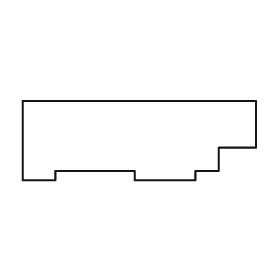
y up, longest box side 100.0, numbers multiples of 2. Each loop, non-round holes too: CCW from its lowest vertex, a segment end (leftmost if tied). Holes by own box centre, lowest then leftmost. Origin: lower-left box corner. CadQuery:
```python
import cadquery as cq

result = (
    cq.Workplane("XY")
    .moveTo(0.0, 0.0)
    .lineTo(14.0, 0.0)
    .lineTo(14.0, 4.0)
    .lineTo(48.0, 4.0)
    .lineTo(48.0, 0.0)
    .lineTo(74.0, 0.0)
    .lineTo(74.0, 4.0)
    .lineTo(84.0, 4.0)
    .lineTo(84.0, 14.0)
    .lineTo(100.0, 14.0)
    .lineTo(100.0, 34.0)
    .lineTo(0.0, 34.0)
    .close()
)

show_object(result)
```